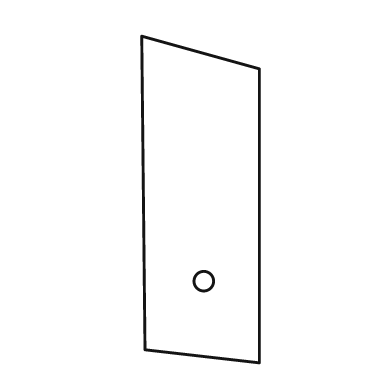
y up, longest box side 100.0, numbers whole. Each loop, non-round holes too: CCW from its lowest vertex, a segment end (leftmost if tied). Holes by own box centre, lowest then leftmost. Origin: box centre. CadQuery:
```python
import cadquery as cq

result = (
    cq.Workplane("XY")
    .moveTo(18.0, -50.0)
    .lineTo(18.0, 40.0)
    .lineTo(-18.0, 50.0)
    .lineTo(-17.0, -46.0)
    .close()
    .moveTo(1.0, -25.0)
    .circle(3.0)
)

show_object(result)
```